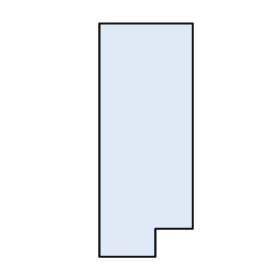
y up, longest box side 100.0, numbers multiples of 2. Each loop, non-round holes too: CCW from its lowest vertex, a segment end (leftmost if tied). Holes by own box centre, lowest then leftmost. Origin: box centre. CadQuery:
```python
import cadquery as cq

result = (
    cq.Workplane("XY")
    .moveTo(-20.0, -50.0)
    .lineTo(4.0, -50.0)
    .lineTo(4.0, -38.0)
    .lineTo(20.0, -38.0)
    .lineTo(20.0, 50.0)
    .lineTo(-20.0, 50.0)
    .close()
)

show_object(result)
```